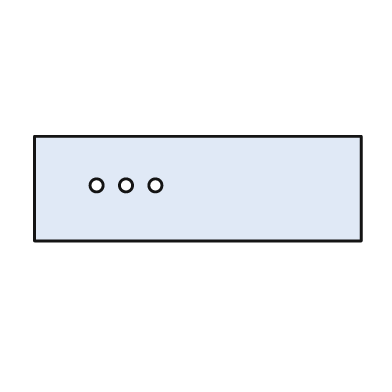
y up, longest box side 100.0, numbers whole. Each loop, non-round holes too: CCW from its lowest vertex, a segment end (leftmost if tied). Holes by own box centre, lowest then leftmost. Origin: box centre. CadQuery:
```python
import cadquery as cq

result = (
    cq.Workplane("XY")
    .moveTo(-50.0, -16.0)
    .lineTo(50.0, -16.0)
    .lineTo(50.0, 16.0)
    .lineTo(-50.0, 16.0)
    .close()
    .moveTo(-31.0, 1.0)
    .circle(2.0)
    .moveTo(-22.0, 1.0)
    .circle(2.0)
    .moveTo(-13.0, 1.0)
    .circle(2.0)
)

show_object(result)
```